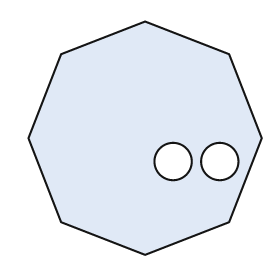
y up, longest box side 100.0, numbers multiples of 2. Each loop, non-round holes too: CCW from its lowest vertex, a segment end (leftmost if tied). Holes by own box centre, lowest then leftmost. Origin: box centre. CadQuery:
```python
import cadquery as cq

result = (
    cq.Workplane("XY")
    .moveTo(0.0, -50.0)
    .lineTo(36.0, -36.0)
    .lineTo(50.0, 0.0)
    .lineTo(36.0, 36.0)
    .lineTo(0.0, 50.0)
    .lineTo(-36.0, 36.0)
    .lineTo(-50.0, 0.0)
    .lineTo(-36.0, -36.0)
    .close()
    .moveTo(12.0, -10.0)
    .circle(8.0)
    .moveTo(32.0, -10.0)
    .circle(8.0)
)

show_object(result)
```